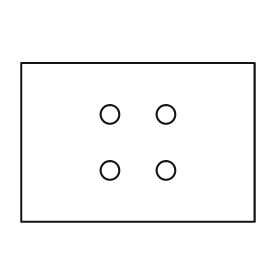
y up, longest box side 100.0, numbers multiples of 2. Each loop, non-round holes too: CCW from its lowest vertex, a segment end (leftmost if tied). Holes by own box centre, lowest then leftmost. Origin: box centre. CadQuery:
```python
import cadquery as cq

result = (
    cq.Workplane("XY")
    .moveTo(-50.0, -34.0)
    .lineTo(50.0, -34.0)
    .lineTo(50.0, 34.0)
    .lineTo(-50.0, 34.0)
    .close()
    .moveTo(-12.0, -12.0)
    .circle(4.0)
    .moveTo(12.0, -12.0)
    .circle(4.0)
    .moveTo(-12.0, 12.0)
    .circle(4.0)
    .moveTo(12.0, 12.0)
    .circle(4.0)
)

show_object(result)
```